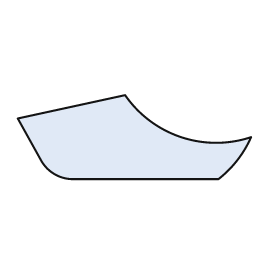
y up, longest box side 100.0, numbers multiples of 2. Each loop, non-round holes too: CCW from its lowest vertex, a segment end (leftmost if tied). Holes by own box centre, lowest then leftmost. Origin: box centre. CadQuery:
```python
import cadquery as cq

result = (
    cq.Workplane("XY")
    .moveTo(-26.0, -18.0)
    .lineTo(36.0, -18.0)
    .threePointArc((44.0, -10.0), (50.0, 0.0))
    .threePointArc((20.0, 0.0), (-4.0, 18.0))
    .lineTo(-50.0, 8.0)
    .lineTo(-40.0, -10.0)
    .threePointArc((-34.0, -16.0), (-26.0, -18.0))
    .close()
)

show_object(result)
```